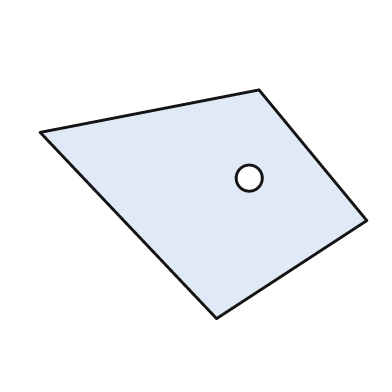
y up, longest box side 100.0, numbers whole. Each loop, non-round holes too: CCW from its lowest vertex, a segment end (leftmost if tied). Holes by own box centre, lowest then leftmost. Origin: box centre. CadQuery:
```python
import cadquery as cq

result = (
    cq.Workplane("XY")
    .moveTo(4.0, -35.0)
    .lineTo(50.0, -5.0)
    .lineTo(17.0, 35.0)
    .lineTo(-50.0, 22.0)
    .close()
    .moveTo(14.0, 8.0)
    .circle(4.0)
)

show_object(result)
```